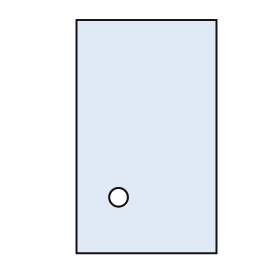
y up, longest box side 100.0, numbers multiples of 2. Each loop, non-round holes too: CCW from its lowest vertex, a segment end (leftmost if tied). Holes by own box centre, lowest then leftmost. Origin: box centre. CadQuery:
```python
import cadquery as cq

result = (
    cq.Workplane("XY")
    .moveTo(-30.0, -50.0)
    .lineTo(30.0, -50.0)
    .lineTo(30.0, 50.0)
    .lineTo(-30.0, 50.0)
    .close()
    .moveTo(-12.0, -26.0)
    .circle(4.0)
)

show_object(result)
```